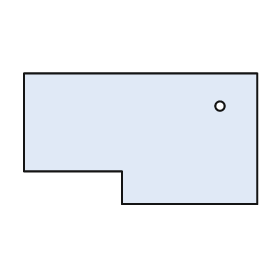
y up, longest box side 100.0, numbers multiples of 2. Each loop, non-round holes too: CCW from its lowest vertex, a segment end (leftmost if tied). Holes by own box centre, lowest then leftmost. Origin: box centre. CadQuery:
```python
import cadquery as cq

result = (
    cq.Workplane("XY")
    .moveTo(-8.0, -28.0)
    .lineTo(50.0, -28.0)
    .lineTo(50.0, 28.0)
    .lineTo(-50.0, 28.0)
    .lineTo(-50.0, -14.0)
    .lineTo(-8.0, -14.0)
    .close()
    .moveTo(34.0, 14.0)
    .circle(2.0)
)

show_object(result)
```